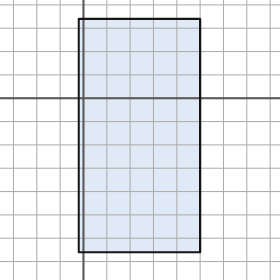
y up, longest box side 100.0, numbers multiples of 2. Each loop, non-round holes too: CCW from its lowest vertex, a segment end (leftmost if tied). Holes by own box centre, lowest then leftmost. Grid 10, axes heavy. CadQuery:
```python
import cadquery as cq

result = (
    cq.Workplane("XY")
    .moveTo(-2.0, -66.0)
    .lineTo(50.0, -66.0)
    .lineTo(50.0, 34.0)
    .lineTo(-2.0, 34.0)
    .close()
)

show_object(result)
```